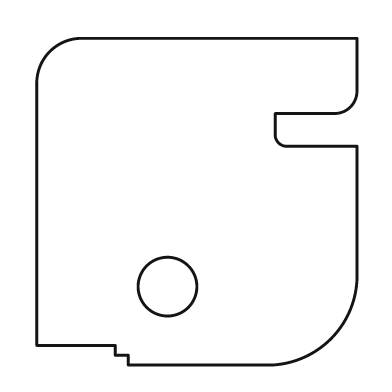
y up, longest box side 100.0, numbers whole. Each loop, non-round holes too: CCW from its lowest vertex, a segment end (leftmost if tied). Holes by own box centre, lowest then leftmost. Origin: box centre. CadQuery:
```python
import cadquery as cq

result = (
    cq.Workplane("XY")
    .moveTo(-21.0, -50.0)
    .lineTo(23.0, -50.0)
    .threePointArc((41.0, -42.0), (49.0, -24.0))
    .lineTo(49.0, 17.0)
    .lineTo(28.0, 17.0)
    .threePointArc((25.0, 18.0), (24.0, 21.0))
    .lineTo(24.0, 27.0)
    .lineTo(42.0, 27.0)
    .threePointArc((47.0, 29.0), (49.0, 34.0))
    .lineTo(49.0, 50.0)
    .lineTo(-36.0, 50.0)
    .threePointArc((-45.0, 46.0), (-49.0, 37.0))
    .lineTo(-49.0, -44.0)
    .lineTo(-25.0, -44.0)
    .lineTo(-25.0, -47.0)
    .lineTo(-21.0, -47.0)
    .close()
    .moveTo(-9.0, -26.0)
    .circle(9.0)
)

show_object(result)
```